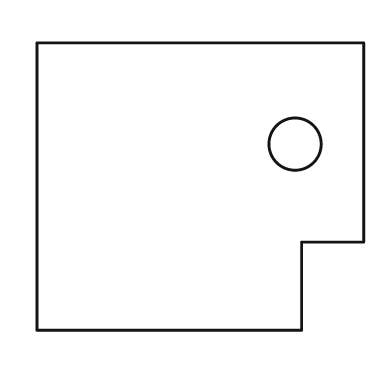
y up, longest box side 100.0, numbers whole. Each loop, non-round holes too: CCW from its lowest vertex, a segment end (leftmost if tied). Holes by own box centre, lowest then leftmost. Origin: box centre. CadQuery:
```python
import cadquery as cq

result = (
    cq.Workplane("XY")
    .moveTo(-50.0, -44.0)
    .lineTo(31.0, -44.0)
    .lineTo(31.0, -17.0)
    .lineTo(50.0, -17.0)
    .lineTo(50.0, 44.0)
    .lineTo(-50.0, 44.0)
    .close()
    .moveTo(29.0, 13.0)
    .circle(8.0)
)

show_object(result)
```